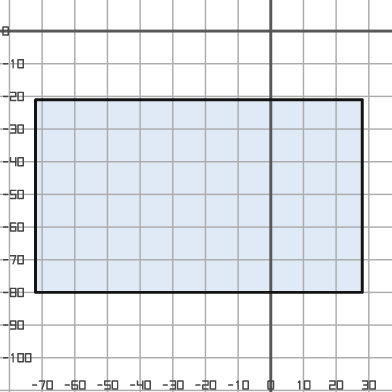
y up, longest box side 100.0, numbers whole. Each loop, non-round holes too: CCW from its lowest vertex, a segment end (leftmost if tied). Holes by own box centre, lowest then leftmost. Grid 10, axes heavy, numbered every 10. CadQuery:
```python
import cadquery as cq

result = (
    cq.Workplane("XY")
    .moveTo(-72.0, -80.0)
    .lineTo(28.0, -80.0)
    .lineTo(28.0, -21.0)
    .lineTo(-72.0, -21.0)
    .close()
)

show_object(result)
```